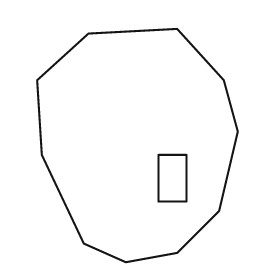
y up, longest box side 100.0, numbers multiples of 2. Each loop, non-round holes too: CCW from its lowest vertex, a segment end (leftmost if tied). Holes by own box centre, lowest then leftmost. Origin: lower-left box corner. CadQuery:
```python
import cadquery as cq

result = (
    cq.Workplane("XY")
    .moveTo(38.0, 0.0)
    .lineTo(60.0, 4.0)
    .lineTo(78.0, 22.0)
    .lineTo(86.0, 56.0)
    .lineTo(80.0, 78.0)
    .lineTo(60.0, 100.0)
    .lineTo(22.0, 98.0)
    .lineTo(0.0, 78.0)
    .lineTo(2.0, 46.0)
    .lineTo(20.0, 8.0)
    .close()
    .moveTo(52.0, 26.0)
    .lineTo(64.0, 26.0)
    .lineTo(64.0, 46.0)
    .lineTo(52.0, 46.0)
    .close()
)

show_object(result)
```